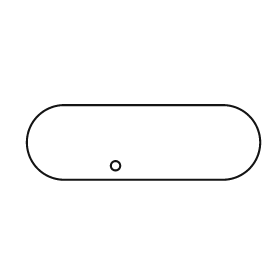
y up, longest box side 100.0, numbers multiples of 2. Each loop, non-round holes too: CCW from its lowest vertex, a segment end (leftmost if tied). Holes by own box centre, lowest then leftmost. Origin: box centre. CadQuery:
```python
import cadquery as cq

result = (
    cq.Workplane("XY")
    .moveTo(-34.0, -16.0)
    .lineTo(34.0, -16.0)
    .threePointArc((50.0, 0.0), (34.0, 16.0))
    .lineTo(-34.0, 16.0)
    .threePointArc((-50.0, 0.0), (-34.0, -16.0))
    .close()
    .moveTo(-12.0, -10.0)
    .circle(2.0)
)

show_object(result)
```